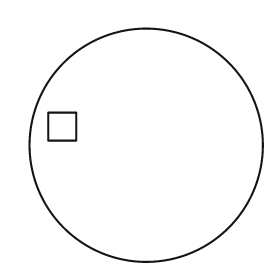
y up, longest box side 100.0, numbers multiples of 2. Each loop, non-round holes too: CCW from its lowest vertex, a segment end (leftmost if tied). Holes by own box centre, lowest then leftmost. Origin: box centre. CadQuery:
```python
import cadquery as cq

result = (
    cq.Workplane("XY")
    .moveTo(0.0, 0.0)
    .circle(50.0)
    .moveTo(-42.0, 2.0)
    .lineTo(-30.0, 2.0)
    .lineTo(-30.0, 14.0)
    .lineTo(-42.0, 14.0)
    .close()
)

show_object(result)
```